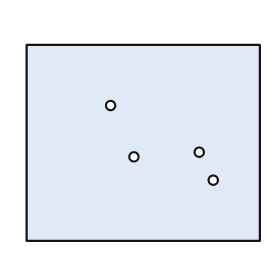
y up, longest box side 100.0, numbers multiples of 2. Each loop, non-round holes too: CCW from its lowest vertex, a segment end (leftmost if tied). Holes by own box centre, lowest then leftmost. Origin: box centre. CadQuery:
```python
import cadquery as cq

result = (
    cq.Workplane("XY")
    .moveTo(-50.0, -42.0)
    .lineTo(50.0, -42.0)
    .lineTo(50.0, 42.0)
    .lineTo(-50.0, 42.0)
    .close()
    .moveTo(30.0, -16.0)
    .circle(2.0)
    .moveTo(-4.0, -6.0)
    .circle(2.0)
    .moveTo(24.0, -4.0)
    .circle(2.0)
    .moveTo(-14.0, 16.0)
    .circle(2.0)
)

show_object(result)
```